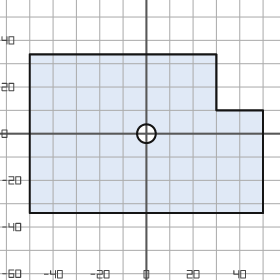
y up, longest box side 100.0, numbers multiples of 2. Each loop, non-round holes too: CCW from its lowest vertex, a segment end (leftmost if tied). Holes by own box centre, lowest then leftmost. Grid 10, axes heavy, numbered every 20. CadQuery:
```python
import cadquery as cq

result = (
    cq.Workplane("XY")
    .moveTo(-50.0, -34.0)
    .lineTo(50.0, -34.0)
    .lineTo(50.0, 10.0)
    .lineTo(30.0, 10.0)
    .lineTo(30.0, 34.0)
    .lineTo(-50.0, 34.0)
    .close()
    .moveTo(0.0, 0.0)
    .circle(4.0)
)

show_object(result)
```